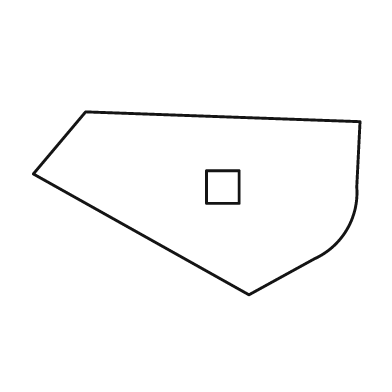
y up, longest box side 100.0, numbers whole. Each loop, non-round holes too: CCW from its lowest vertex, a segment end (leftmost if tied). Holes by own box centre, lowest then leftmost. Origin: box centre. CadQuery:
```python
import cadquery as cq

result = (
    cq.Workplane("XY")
    .moveTo(16.0, -28.0)
    .lineTo(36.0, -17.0)
    .threePointArc((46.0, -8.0), (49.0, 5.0))
    .lineTo(50.0, 25.0)
    .lineTo(-34.0, 28.0)
    .lineTo(-50.0, 9.0)
    .close()
    .moveTo(3.0, 0.0)
    .lineTo(13.0, 0.0)
    .lineTo(13.0, 10.0)
    .lineTo(3.0, 10.0)
    .close()
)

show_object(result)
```